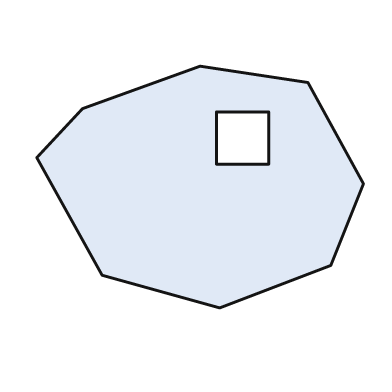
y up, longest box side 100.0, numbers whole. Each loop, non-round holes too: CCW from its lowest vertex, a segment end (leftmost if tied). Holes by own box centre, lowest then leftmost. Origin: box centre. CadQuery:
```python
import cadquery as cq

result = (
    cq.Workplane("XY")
    .moveTo(6.0, -37.0)
    .lineTo(40.0, -24.0)
    .lineTo(50.0, 1.0)
    .lineTo(33.0, 32.0)
    .lineTo(0.0, 37.0)
    .lineTo(-36.0, 24.0)
    .lineTo(-50.0, 9.0)
    .lineTo(-30.0, -27.0)
    .close()
    .moveTo(5.0, 7.0)
    .lineTo(21.0, 7.0)
    .lineTo(21.0, 23.0)
    .lineTo(5.0, 23.0)
    .close()
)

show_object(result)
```